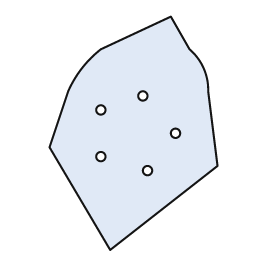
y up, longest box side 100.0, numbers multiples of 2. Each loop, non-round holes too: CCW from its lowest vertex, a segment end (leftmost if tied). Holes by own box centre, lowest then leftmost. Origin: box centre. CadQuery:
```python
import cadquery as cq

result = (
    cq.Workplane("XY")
    .moveTo(-10.0, -50.0)
    .lineTo(36.0, -14.0)
    .lineTo(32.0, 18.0)
    .threePointArc((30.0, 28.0), (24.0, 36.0))
    .lineTo(16.0, 50.0)
    .lineTo(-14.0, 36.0)
    .threePointArc((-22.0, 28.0), (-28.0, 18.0))
    .lineTo(-36.0, -6.0)
    .close()
    .moveTo(6.0, -16.0)
    .circle(2.0)
    .moveTo(-14.0, -10.0)
    .circle(2.0)
    .moveTo(18.0, 0.0)
    .circle(2.0)
    .moveTo(-14.0, 10.0)
    .circle(2.0)
    .moveTo(4.0, 16.0)
    .circle(2.0)
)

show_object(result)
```